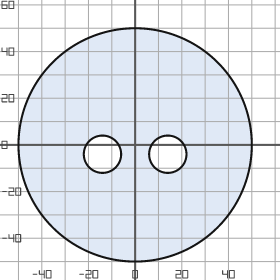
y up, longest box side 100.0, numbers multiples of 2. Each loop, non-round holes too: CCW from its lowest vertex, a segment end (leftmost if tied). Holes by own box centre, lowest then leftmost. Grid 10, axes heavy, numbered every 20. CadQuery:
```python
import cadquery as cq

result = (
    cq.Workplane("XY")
    .moveTo(0.0, 0.0)
    .circle(50.0)
    .moveTo(-14.0, -4.0)
    .circle(8.0)
    .moveTo(14.0, -4.0)
    .circle(8.0)
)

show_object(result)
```